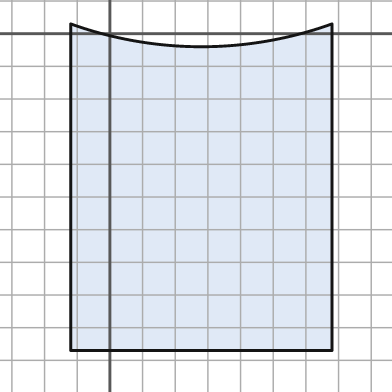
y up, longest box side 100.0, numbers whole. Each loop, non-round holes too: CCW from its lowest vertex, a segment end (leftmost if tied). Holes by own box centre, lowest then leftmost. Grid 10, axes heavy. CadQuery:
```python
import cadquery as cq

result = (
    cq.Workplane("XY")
    .moveTo(-12.0, -97.0)
    .lineTo(68.0, -97.0)
    .lineTo(68.0, 3.0)
    .threePointArc((28.0, -4.0), (-12.0, 3.0))
    .close()
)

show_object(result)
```